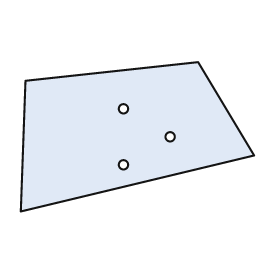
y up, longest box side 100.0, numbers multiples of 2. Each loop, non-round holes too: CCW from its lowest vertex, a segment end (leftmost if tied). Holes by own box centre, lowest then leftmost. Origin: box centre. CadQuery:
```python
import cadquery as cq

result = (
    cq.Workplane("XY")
    .moveTo(-50.0, -32.0)
    .lineTo(50.0, -8.0)
    .lineTo(26.0, 32.0)
    .lineTo(-48.0, 24.0)
    .close()
    .moveTo(-6.0, -12.0)
    .circle(2.0)
    .moveTo(14.0, 0.0)
    .circle(2.0)
    .moveTo(-6.0, 12.0)
    .circle(2.0)
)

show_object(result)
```